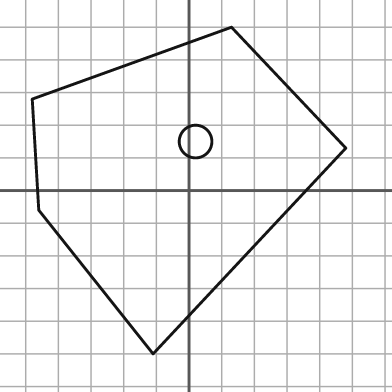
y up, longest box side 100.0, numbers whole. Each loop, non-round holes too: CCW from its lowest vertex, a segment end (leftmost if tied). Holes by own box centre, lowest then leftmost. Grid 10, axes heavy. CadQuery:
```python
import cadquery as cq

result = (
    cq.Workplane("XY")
    .moveTo(-11.0, -50.0)
    .lineTo(48.0, 13.0)
    .lineTo(13.0, 50.0)
    .lineTo(-48.0, 28.0)
    .lineTo(-46.0, -6.0)
    .close()
    .moveTo(2.0, 15.0)
    .circle(5.0)
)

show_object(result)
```